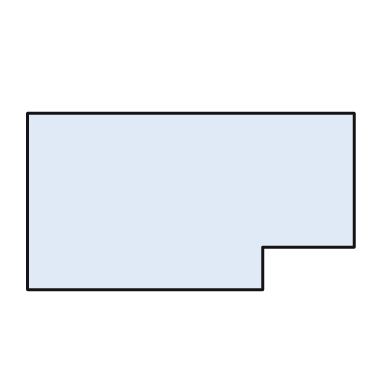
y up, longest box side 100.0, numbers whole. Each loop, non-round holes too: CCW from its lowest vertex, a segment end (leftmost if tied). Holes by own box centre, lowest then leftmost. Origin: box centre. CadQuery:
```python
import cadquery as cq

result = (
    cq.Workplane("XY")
    .moveTo(-50.0, -27.0)
    .lineTo(22.0, -27.0)
    .lineTo(22.0, -14.0)
    .lineTo(50.0, -14.0)
    .lineTo(50.0, 27.0)
    .lineTo(-50.0, 27.0)
    .close()
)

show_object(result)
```